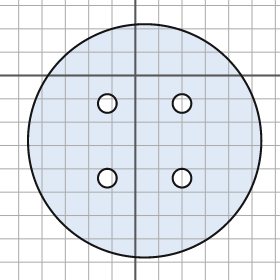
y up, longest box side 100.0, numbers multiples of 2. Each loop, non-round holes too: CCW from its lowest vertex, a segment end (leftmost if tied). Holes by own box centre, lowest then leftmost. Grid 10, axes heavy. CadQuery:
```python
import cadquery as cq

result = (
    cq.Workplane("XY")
    .moveTo(4.0, -28.0)
    .circle(50.0)
    .moveTo(-12.0, -44.0)
    .circle(4.0)
    .moveTo(20.0, -44.0)
    .circle(4.0)
    .moveTo(-12.0, -12.0)
    .circle(4.0)
    .moveTo(20.0, -12.0)
    .circle(4.0)
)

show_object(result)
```